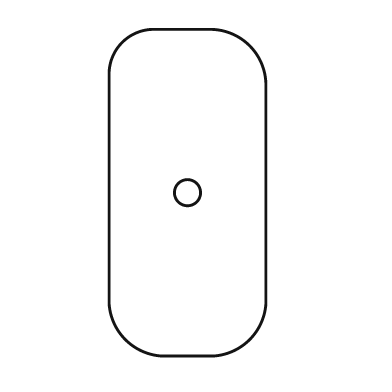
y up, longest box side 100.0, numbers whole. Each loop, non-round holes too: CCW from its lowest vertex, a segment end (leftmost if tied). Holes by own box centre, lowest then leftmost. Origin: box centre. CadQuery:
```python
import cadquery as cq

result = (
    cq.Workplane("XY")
    .moveTo(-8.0, -50.0)
    .lineTo(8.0, -50.0)
    .threePointArc((19.0, -45.0), (24.0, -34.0))
    .lineTo(24.0, 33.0)
    .threePointArc((19.0, 45.0), (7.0, 50.0))
    .lineTo(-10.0, 50.0)
    .threePointArc((-20.0, 46.0), (-24.0, 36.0))
    .lineTo(-24.0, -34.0)
    .threePointArc((-19.0, -45.0), (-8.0, -50.0))
    .close()
    .moveTo(0.0, 0.0)
    .circle(4.0)
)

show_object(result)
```